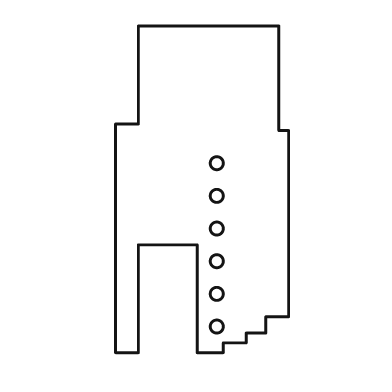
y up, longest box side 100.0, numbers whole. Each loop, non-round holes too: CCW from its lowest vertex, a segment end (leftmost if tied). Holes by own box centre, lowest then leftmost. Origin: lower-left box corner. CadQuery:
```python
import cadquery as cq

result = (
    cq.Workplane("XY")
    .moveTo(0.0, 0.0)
    .lineTo(7.0, 0.0)
    .lineTo(7.0, 33.0)
    .lineTo(25.0, 33.0)
    .lineTo(25.0, 0.0)
    .lineTo(33.0, 0.0)
    .lineTo(33.0, 3.0)
    .lineTo(40.0, 3.0)
    .lineTo(40.0, 6.0)
    .lineTo(46.0, 6.0)
    .lineTo(46.0, 11.0)
    .lineTo(53.0, 11.0)
    .lineTo(53.0, 68.0)
    .lineTo(50.0, 68.0)
    .lineTo(50.0, 100.0)
    .lineTo(7.0, 100.0)
    .lineTo(7.0, 70.0)
    .lineTo(0.0, 70.0)
    .close()
    .moveTo(31.0, 8.0)
    .circle(2.0)
    .moveTo(31.0, 18.0)
    .circle(2.0)
    .moveTo(31.0, 28.0)
    .circle(2.0)
    .moveTo(31.0, 38.0)
    .circle(2.0)
    .moveTo(31.0, 48.0)
    .circle(2.0)
    .moveTo(31.0, 58.0)
    .circle(2.0)
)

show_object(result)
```